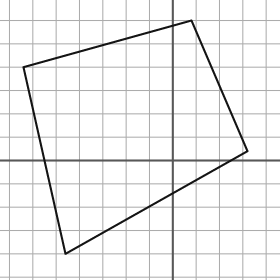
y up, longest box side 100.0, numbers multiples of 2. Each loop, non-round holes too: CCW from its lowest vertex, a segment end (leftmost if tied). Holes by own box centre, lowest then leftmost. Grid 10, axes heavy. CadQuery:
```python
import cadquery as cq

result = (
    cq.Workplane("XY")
    .moveTo(-46.0, -40.0)
    .lineTo(32.0, 4.0)
    .lineTo(8.0, 60.0)
    .lineTo(-64.0, 40.0)
    .close()
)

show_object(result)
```